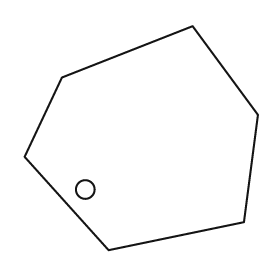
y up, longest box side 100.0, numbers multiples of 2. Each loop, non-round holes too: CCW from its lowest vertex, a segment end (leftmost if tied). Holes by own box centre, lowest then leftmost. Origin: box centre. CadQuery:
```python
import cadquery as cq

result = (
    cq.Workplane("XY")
    .moveTo(-14.0, -48.0)
    .lineTo(44.0, -36.0)
    .lineTo(50.0, 10.0)
    .lineTo(22.0, 48.0)
    .lineTo(-34.0, 26.0)
    .lineTo(-50.0, -8.0)
    .close()
    .moveTo(-24.0, -22.0)
    .circle(4.0)
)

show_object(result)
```